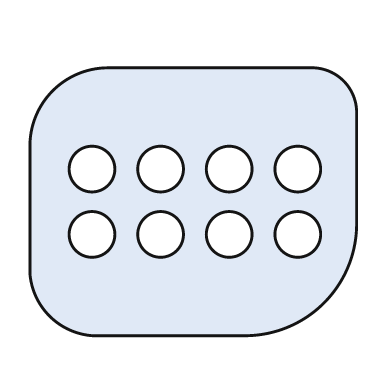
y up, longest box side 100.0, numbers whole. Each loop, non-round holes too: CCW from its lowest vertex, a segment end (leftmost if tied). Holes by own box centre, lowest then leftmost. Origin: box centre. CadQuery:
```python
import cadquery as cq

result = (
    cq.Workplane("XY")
    .moveTo(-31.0, -41.0)
    .lineTo(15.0, -41.0)
    .threePointArc((40.0, -31.0), (50.0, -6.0))
    .lineTo(50.0, 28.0)
    .threePointArc((46.0, 37.0), (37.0, 41.0))
    .lineTo(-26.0, 41.0)
    .threePointArc((-43.0, 34.0), (-50.0, 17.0))
    .lineTo(-50.0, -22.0)
    .threePointArc((-44.0, -35.0), (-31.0, -41.0))
    .close()
    .moveTo(-31.0, -10.0)
    .circle(7.0)
    .moveTo(-10.0, -10.0)
    .circle(7.0)
    .moveTo(11.0, -10.0)
    .circle(7.0)
    .moveTo(32.0, -10.0)
    .circle(7.0)
    .moveTo(-31.0, 10.0)
    .circle(7.0)
    .moveTo(-10.0, 10.0)
    .circle(7.0)
    .moveTo(11.0, 10.0)
    .circle(7.0)
    .moveTo(32.0, 10.0)
    .circle(7.0)
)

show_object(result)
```